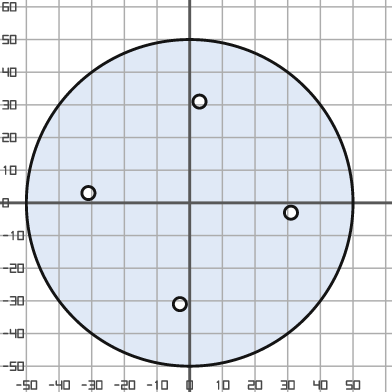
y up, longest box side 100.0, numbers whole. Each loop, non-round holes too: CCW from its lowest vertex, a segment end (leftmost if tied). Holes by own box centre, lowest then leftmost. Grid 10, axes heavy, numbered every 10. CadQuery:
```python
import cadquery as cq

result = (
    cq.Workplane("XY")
    .moveTo(0.0, 0.0)
    .circle(50.0)
    .moveTo(-3.0, -31.0)
    .circle(2.0)
    .moveTo(31.0, -3.0)
    .circle(2.0)
    .moveTo(-31.0, 3.0)
    .circle(2.0)
    .moveTo(3.0, 31.0)
    .circle(2.0)
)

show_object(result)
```